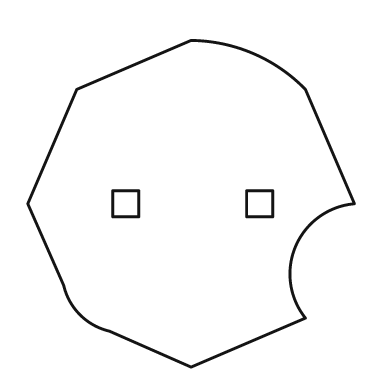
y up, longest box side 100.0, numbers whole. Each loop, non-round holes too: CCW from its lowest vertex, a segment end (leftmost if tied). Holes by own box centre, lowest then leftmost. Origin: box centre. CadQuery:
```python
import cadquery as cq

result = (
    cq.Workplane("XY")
    .moveTo(0.0, -50.0)
    .lineTo(35.0, -35.0)
    .threePointArc((32.0, -13.0), (50.0, 0.0))
    .lineTo(35.0, 35.0)
    .threePointArc((19.0, 46.0), (0.0, 50.0))
    .lineTo(-35.0, 35.0)
    .lineTo(-50.0, 0.0)
    .lineTo(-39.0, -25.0)
    .threePointArc((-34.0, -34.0), (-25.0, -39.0))
    .close()
    .moveTo(-24.0, -4.0)
    .lineTo(-16.0, -4.0)
    .lineTo(-16.0, 4.0)
    .lineTo(-24.0, 4.0)
    .close()
    .moveTo(17.0, -4.0)
    .lineTo(25.0, -4.0)
    .lineTo(25.0, 4.0)
    .lineTo(17.0, 4.0)
    .close()
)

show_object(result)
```